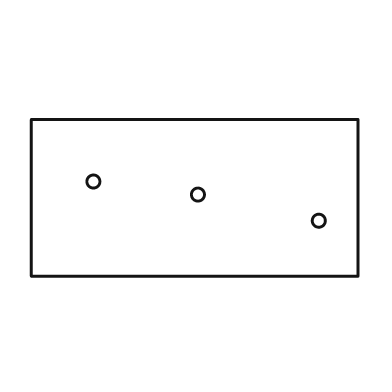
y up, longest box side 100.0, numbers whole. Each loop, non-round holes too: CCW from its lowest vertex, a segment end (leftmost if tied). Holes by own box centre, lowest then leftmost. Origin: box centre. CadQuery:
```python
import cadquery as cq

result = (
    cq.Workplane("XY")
    .moveTo(-50.0, -24.0)
    .lineTo(50.0, -24.0)
    .lineTo(50.0, 24.0)
    .lineTo(-50.0, 24.0)
    .close()
    .moveTo(38.0, -7.0)
    .circle(2.0)
    .moveTo(1.0, 1.0)
    .circle(2.0)
    .moveTo(-31.0, 5.0)
    .circle(2.0)
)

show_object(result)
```